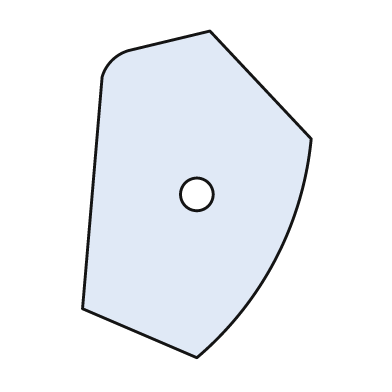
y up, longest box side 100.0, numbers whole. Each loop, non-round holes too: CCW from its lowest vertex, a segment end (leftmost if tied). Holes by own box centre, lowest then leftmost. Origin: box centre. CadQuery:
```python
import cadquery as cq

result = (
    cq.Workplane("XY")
    .moveTo(0.0, -50.0)
    .threePointArc((24.0, -20.0), (35.0, 17.0))
    .lineTo(4.0, 50.0)
    .lineTo(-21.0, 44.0)
    .threePointArc((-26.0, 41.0), (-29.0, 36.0))
    .lineTo(-35.0, -35.0)
    .close()
    .moveTo(0.0, 0.0)
    .circle(5.0)
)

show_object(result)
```